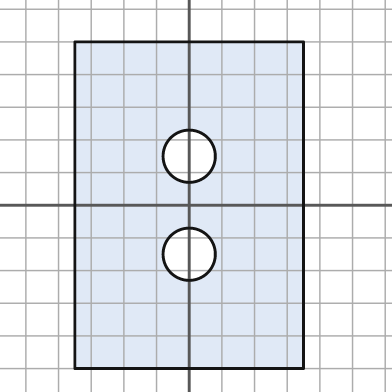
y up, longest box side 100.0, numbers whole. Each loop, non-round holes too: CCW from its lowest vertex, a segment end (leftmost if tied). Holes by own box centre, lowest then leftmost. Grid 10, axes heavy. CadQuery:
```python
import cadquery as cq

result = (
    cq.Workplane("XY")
    .moveTo(-35.0, -50.0)
    .lineTo(35.0, -50.0)
    .lineTo(35.0, 50.0)
    .lineTo(-35.0, 50.0)
    .close()
    .moveTo(0.0, -15.0)
    .circle(8.0)
    .moveTo(0.0, 15.0)
    .circle(8.0)
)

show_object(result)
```